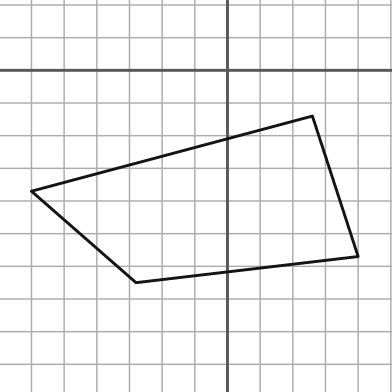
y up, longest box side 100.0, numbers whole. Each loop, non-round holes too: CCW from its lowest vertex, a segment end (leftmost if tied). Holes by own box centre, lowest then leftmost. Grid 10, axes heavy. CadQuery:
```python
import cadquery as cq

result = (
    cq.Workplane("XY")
    .moveTo(-28.0, -65.0)
    .lineTo(40.0, -57.0)
    .lineTo(26.0, -14.0)
    .lineTo(-60.0, -37.0)
    .close()
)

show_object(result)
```